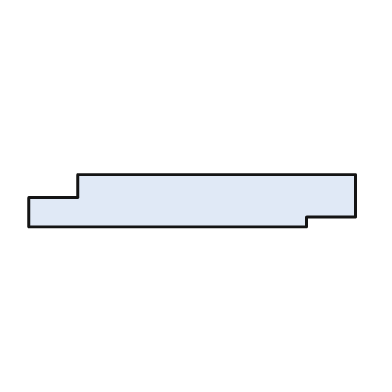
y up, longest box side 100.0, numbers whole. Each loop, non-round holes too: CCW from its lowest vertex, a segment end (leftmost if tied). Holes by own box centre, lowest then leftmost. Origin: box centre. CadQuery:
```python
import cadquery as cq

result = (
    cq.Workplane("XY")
    .moveTo(-50.0, -8.0)
    .lineTo(35.0, -8.0)
    .lineTo(35.0, -5.0)
    .lineTo(50.0, -5.0)
    .lineTo(50.0, 8.0)
    .lineTo(-35.0, 8.0)
    .lineTo(-35.0, 1.0)
    .lineTo(-50.0, 1.0)
    .close()
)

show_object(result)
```